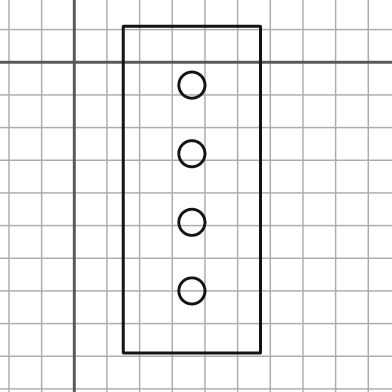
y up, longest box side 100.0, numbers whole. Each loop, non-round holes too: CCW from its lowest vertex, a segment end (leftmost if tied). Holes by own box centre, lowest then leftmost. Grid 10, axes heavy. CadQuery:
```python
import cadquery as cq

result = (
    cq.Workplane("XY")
    .moveTo(15.0, -89.0)
    .lineTo(57.0, -89.0)
    .lineTo(57.0, 11.0)
    .lineTo(15.0, 11.0)
    .close()
    .moveTo(36.0, -70.0)
    .circle(4.0)
    .moveTo(36.0, -49.0)
    .circle(4.0)
    .moveTo(36.0, -28.0)
    .circle(4.0)
    .moveTo(36.0, -7.0)
    .circle(4.0)
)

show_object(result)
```